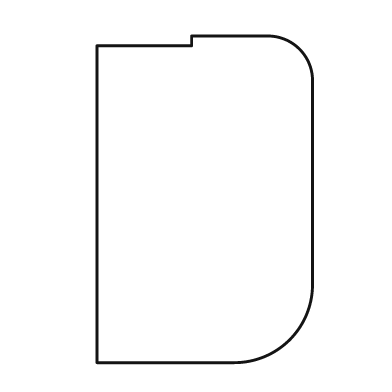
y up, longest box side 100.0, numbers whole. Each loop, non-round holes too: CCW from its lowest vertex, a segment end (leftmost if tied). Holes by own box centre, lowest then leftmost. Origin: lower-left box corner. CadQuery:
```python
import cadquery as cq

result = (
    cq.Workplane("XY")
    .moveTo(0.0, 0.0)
    .lineTo(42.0, 0.0)
    .threePointArc((59.0, 7.0), (66.0, 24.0))
    .lineTo(66.0, 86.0)
    .threePointArc((62.0, 96.0), (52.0, 100.0))
    .lineTo(29.0, 100.0)
    .lineTo(29.0, 97.0)
    .lineTo(0.0, 97.0)
    .close()
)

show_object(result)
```